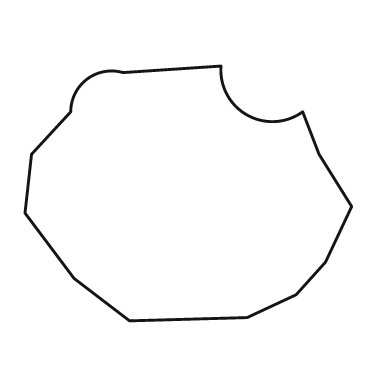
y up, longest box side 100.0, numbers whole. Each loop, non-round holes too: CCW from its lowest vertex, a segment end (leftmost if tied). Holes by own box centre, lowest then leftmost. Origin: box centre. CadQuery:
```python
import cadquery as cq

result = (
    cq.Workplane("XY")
    .moveTo(-18.0, -39.0)
    .lineTo(18.0, -38.0)
    .lineTo(33.0, -31.0)
    .lineTo(42.0, -21.0)
    .lineTo(50.0, -4.0)
    .lineTo(40.0, 12.0)
    .lineTo(35.0, 25.0)
    .threePointArc((18.0, 24.0), (10.0, 39.0))
    .lineTo(-20.0, 37.0)
    .threePointArc((-31.0, 35.0), (-36.0, 25.0))
    .lineTo(-48.0, 12.0)
    .lineTo(-50.0, -6.0)
    .lineTo(-35.0, -26.0)
    .close()
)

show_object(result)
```